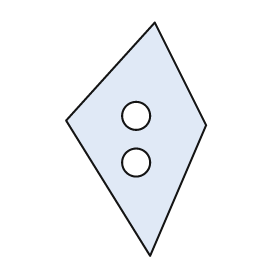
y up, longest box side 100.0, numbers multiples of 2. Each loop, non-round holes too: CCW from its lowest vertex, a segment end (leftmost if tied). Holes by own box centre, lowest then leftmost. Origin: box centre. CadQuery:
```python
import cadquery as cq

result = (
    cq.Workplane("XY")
    .moveTo(6.0, -50.0)
    .lineTo(30.0, 6.0)
    .lineTo(8.0, 50.0)
    .lineTo(-30.0, 8.0)
    .close()
    .moveTo(0.0, -10.0)
    .circle(6.0)
    .moveTo(0.0, 10.0)
    .circle(6.0)
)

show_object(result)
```